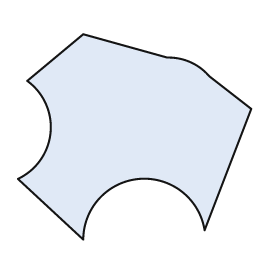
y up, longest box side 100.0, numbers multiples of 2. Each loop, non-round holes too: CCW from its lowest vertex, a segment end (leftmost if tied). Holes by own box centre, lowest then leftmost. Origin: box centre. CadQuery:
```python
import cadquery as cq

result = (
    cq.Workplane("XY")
    .moveTo(-22.0, -44.0)
    .threePointArc((2.0, -18.0), (30.0, -40.0))
    .lineTo(50.0, 12.0)
    .lineTo(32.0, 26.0)
    .threePointArc((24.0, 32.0), (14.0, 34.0))
    .lineTo(-22.0, 44.0)
    .lineTo(-46.0, 24.0)
    .threePointArc((-36.0, 2.0), (-50.0, -18.0))
    .close()
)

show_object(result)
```